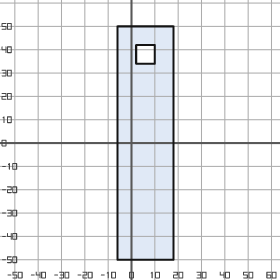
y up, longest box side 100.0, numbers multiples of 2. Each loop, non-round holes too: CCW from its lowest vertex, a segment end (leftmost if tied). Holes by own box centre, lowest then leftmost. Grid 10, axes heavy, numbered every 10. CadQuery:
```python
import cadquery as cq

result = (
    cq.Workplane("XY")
    .moveTo(-6.0, -50.0)
    .lineTo(18.0, -50.0)
    .lineTo(18.0, 50.0)
    .lineTo(-6.0, 50.0)
    .close()
    .moveTo(2.0, 34.0)
    .lineTo(10.0, 34.0)
    .lineTo(10.0, 42.0)
    .lineTo(2.0, 42.0)
    .close()
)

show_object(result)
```